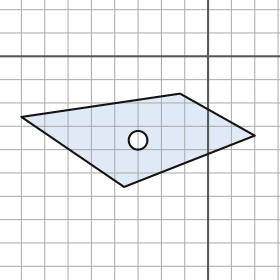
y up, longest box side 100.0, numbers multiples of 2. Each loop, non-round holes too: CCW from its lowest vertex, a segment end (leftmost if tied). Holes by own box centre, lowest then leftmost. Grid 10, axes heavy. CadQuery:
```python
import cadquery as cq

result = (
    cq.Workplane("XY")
    .moveTo(-36.0, -56.0)
    .lineTo(20.0, -34.0)
    .lineTo(-12.0, -16.0)
    .lineTo(-80.0, -26.0)
    .close()
    .moveTo(-30.0, -36.0)
    .circle(4.0)
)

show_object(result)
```